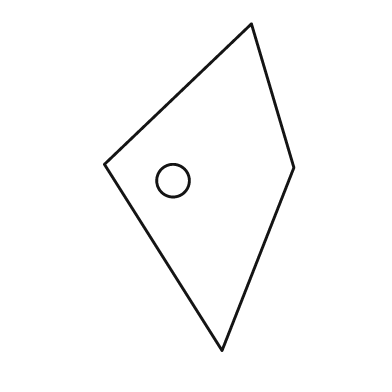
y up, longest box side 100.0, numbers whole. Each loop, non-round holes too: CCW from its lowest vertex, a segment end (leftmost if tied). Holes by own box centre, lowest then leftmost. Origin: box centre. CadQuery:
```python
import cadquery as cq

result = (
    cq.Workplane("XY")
    .moveTo(7.0, -50.0)
    .lineTo(29.0, 6.0)
    .lineTo(16.0, 50.0)
    .lineTo(-29.0, 7.0)
    .close()
    .moveTo(-8.0, 2.0)
    .circle(5.0)
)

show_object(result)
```